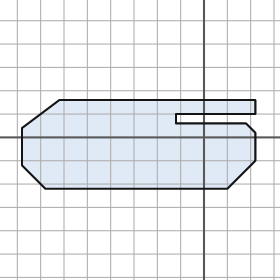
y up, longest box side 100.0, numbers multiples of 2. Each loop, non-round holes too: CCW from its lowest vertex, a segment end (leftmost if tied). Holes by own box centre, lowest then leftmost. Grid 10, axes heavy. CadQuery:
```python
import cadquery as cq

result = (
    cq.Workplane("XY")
    .moveTo(-68.0, -22.0)
    .lineTo(10.0, -22.0)
    .lineTo(22.0, -10.0)
    .lineTo(22.0, 2.0)
    .lineTo(18.0, 6.0)
    .lineTo(-12.0, 6.0)
    .lineTo(-12.0, 10.0)
    .lineTo(22.0, 10.0)
    .lineTo(22.0, 16.0)
    .lineTo(-62.0, 16.0)
    .lineTo(-78.0, 4.0)
    .lineTo(-78.0, -12.0)
    .close()
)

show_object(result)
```